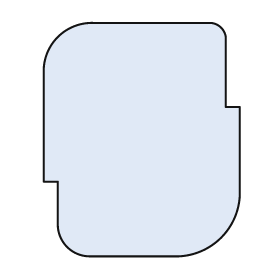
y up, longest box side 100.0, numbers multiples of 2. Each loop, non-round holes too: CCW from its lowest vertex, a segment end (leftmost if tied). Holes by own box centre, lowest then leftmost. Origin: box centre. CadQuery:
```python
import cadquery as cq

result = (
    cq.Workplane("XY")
    .moveTo(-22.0, -50.0)
    .lineTo(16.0, -50.0)
    .threePointArc((34.0, -42.0), (42.0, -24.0))
    .lineTo(42.0, 14.0)
    .lineTo(36.0, 14.0)
    .lineTo(36.0, 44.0)
    .threePointArc((34.0, 48.0), (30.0, 50.0))
    .lineTo(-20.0, 50.0)
    .threePointArc((-36.0, 44.0), (-42.0, 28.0))
    .lineTo(-42.0, -18.0)
    .lineTo(-36.0, -18.0)
    .lineTo(-36.0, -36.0)
    .threePointArc((-32.0, -46.0), (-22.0, -50.0))
    .close()
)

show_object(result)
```